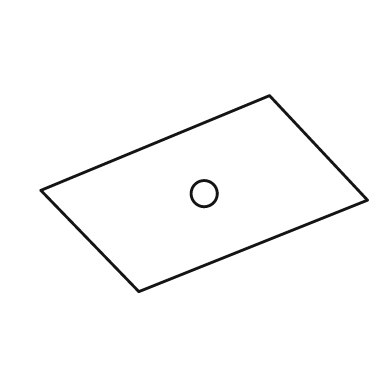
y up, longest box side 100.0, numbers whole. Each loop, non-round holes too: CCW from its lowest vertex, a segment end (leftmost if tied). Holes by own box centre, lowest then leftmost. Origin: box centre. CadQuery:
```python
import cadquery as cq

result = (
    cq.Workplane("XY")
    .moveTo(-20.0, -30.0)
    .lineTo(50.0, -2.0)
    .lineTo(20.0, 30.0)
    .lineTo(-50.0, 1.0)
    .close()
    .moveTo(0.0, 0.0)
    .circle(4.0)
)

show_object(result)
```